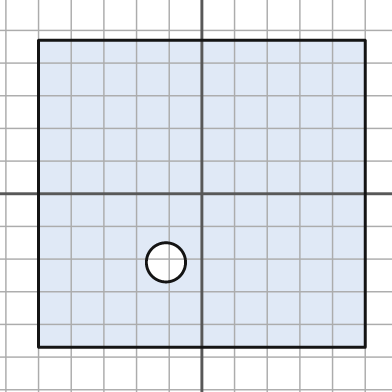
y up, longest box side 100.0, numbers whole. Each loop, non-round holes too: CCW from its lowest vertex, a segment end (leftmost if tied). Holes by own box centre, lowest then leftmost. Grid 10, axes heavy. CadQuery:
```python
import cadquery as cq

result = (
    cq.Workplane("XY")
    .moveTo(-50.0, -47.0)
    .lineTo(50.0, -47.0)
    .lineTo(50.0, 47.0)
    .lineTo(-50.0, 47.0)
    .close()
    .moveTo(-11.0, -21.0)
    .circle(6.0)
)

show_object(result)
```